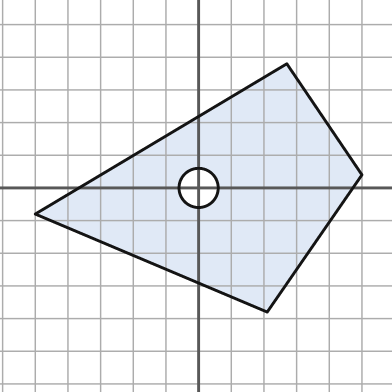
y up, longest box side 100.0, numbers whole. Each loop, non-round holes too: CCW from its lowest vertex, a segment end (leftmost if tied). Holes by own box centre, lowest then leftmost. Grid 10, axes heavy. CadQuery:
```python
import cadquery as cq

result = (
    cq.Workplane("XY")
    .moveTo(21.0, -38.0)
    .lineTo(50.0, 4.0)
    .lineTo(27.0, 38.0)
    .lineTo(-50.0, -8.0)
    .close()
    .moveTo(0.0, 0.0)
    .circle(6.0)
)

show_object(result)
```